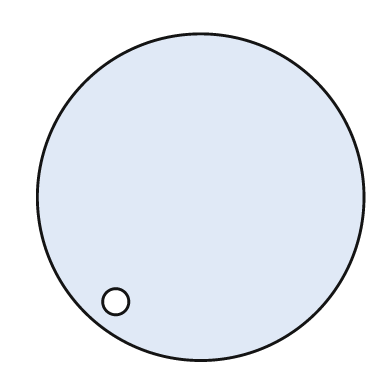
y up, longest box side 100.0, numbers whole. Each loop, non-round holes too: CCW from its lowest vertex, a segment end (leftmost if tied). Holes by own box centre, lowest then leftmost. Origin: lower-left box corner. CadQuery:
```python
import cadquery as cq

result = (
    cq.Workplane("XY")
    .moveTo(50.0, 50.0)
    .circle(50.0)
    .moveTo(24.0, 18.0)
    .circle(4.0)
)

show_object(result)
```